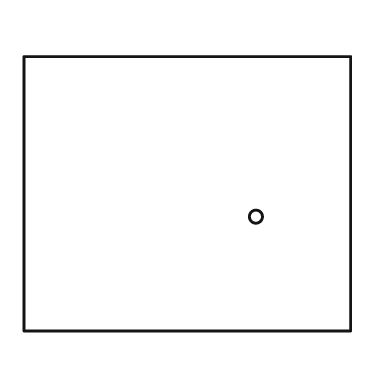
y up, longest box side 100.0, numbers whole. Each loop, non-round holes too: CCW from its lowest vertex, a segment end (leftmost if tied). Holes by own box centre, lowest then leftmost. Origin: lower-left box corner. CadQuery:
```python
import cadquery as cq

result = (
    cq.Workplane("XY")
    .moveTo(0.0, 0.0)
    .lineTo(100.0, 0.0)
    .lineTo(100.0, 84.0)
    .lineTo(0.0, 84.0)
    .close()
    .moveTo(71.0, 35.0)
    .circle(2.0)
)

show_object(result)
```